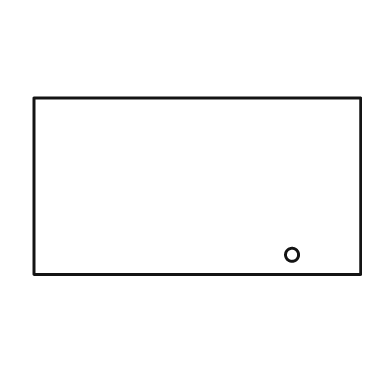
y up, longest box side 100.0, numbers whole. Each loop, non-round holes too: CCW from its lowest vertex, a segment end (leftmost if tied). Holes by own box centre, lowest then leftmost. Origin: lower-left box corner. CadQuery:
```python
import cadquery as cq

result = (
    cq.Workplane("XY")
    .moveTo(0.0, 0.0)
    .lineTo(100.0, 0.0)
    .lineTo(100.0, 54.0)
    .lineTo(0.0, 54.0)
    .close()
    .moveTo(79.0, 6.0)
    .circle(2.0)
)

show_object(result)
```